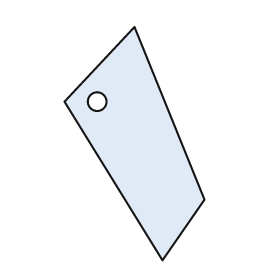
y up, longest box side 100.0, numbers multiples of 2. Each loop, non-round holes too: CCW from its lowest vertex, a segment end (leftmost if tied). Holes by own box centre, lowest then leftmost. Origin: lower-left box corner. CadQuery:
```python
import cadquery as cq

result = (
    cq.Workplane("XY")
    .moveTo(42.0, 0.0)
    .lineTo(60.0, 26.0)
    .lineTo(30.0, 100.0)
    .lineTo(0.0, 68.0)
    .close()
    .moveTo(14.0, 68.0)
    .circle(4.0)
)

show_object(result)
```